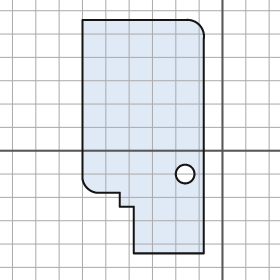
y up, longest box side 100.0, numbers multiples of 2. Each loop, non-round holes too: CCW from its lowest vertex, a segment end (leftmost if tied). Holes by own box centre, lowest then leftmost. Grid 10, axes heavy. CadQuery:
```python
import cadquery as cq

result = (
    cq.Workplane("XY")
    .moveTo(-38.0, -44.0)
    .lineTo(-8.0, -44.0)
    .lineTo(-8.0, 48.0)
    .threePointArc((-10.0, 54.0), (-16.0, 56.0))
    .lineTo(-60.0, 56.0)
    .lineTo(-60.0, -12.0)
    .threePointArc((-58.0, -16.0), (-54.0, -18.0))
    .lineTo(-44.0, -18.0)
    .lineTo(-44.0, -24.0)
    .lineTo(-38.0, -24.0)
    .close()
    .moveTo(-16.0, -10.0)
    .circle(4.0)
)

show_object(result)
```